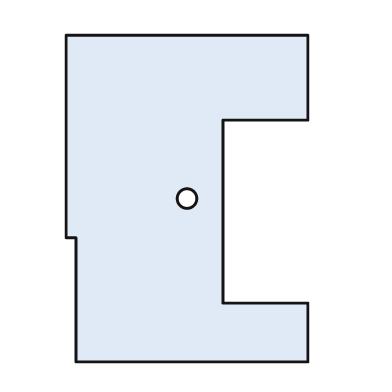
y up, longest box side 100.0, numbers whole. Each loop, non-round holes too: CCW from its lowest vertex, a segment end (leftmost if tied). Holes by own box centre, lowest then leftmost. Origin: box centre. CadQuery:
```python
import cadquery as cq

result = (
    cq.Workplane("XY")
    .moveTo(-34.0, -50.0)
    .lineTo(37.0, -50.0)
    .lineTo(37.0, -32.0)
    .lineTo(11.0, -32.0)
    .lineTo(11.0, 24.0)
    .lineTo(37.0, 24.0)
    .lineTo(37.0, 50.0)
    .lineTo(-37.0, 50.0)
    .lineTo(-37.0, -12.0)
    .lineTo(-34.0, -12.0)
    .close()
    .moveTo(0.0, 0.0)
    .circle(3.0)
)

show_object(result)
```